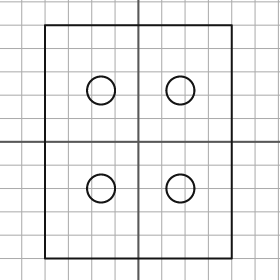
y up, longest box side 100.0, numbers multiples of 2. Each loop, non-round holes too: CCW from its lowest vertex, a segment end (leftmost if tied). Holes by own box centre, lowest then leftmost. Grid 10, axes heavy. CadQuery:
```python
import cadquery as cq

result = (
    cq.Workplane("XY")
    .moveTo(-40.0, -50.0)
    .lineTo(40.0, -50.0)
    .lineTo(40.0, 50.0)
    .lineTo(-40.0, 50.0)
    .close()
    .moveTo(-16.0, -20.0)
    .circle(6.0)
    .moveTo(18.0, -20.0)
    .circle(6.0)
    .moveTo(-16.0, 22.0)
    .circle(6.0)
    .moveTo(18.0, 22.0)
    .circle(6.0)
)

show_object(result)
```